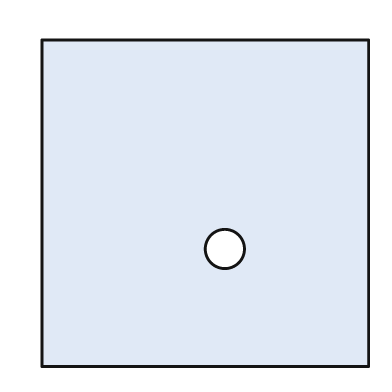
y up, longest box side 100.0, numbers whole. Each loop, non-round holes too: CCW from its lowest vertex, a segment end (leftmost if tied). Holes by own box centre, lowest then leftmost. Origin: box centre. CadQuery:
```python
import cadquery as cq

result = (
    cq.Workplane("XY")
    .moveTo(-50.0, -50.0)
    .lineTo(50.0, -50.0)
    .lineTo(50.0, 50.0)
    .lineTo(-50.0, 50.0)
    .close()
    .moveTo(6.0, -14.0)
    .circle(6.0)
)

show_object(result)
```